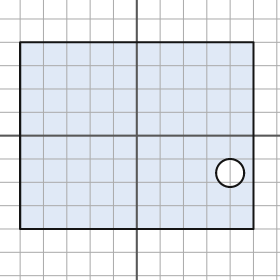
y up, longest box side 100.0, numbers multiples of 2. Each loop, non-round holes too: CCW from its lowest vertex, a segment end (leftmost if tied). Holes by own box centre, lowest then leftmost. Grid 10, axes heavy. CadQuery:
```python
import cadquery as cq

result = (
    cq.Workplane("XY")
    .moveTo(-50.0, -40.0)
    .lineTo(50.0, -40.0)
    .lineTo(50.0, 40.0)
    .lineTo(-50.0, 40.0)
    .close()
    .moveTo(40.0, -16.0)
    .circle(6.0)
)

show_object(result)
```